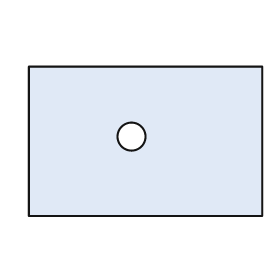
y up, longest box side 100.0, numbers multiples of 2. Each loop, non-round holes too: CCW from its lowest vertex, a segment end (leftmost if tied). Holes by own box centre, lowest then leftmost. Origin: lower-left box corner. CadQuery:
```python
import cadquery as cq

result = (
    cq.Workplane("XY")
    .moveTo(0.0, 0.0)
    .lineTo(100.0, 0.0)
    .lineTo(100.0, 64.0)
    .lineTo(0.0, 64.0)
    .close()
    .moveTo(44.0, 34.0)
    .circle(6.0)
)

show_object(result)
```